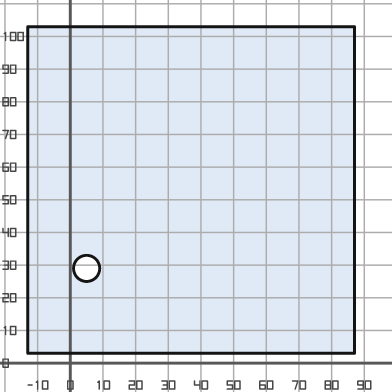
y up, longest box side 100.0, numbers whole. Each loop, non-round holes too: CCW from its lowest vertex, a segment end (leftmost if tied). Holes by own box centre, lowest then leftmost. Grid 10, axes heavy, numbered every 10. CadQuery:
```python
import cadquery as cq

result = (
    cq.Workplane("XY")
    .moveTo(-13.0, 3.0)
    .lineTo(87.0, 3.0)
    .lineTo(87.0, 103.0)
    .lineTo(-13.0, 103.0)
    .close()
    .moveTo(5.0, 29.0)
    .circle(4.0)
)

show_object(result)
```